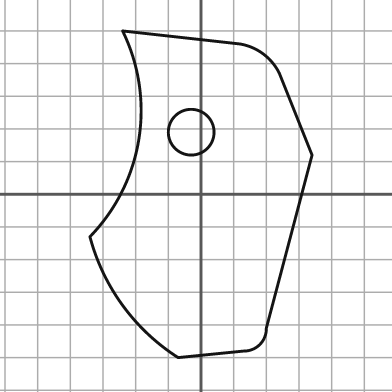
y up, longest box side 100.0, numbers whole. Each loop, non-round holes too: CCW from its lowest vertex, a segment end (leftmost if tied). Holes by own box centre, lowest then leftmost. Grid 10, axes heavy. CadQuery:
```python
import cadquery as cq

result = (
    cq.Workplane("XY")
    .moveTo(-7.0, -50.0)
    .lineTo(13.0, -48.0)
    .threePointArc((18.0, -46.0), (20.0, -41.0))
    .lineTo(34.0, 12.0)
    .lineTo(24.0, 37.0)
    .threePointArc((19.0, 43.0), (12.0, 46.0))
    .lineTo(-24.0, 50.0)
    .threePointArc((-19.0, 17.0), (-34.0, -13.0))
    .threePointArc((-24.0, -34.0), (-7.0, -50.0))
    .close()
    .moveTo(-3.0, 19.0)
    .circle(7.0)
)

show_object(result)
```